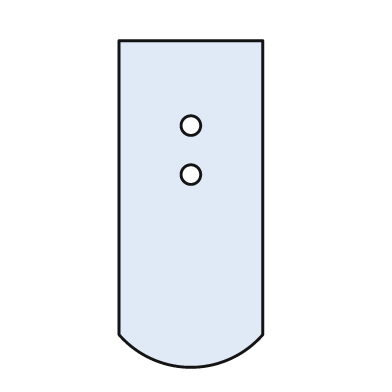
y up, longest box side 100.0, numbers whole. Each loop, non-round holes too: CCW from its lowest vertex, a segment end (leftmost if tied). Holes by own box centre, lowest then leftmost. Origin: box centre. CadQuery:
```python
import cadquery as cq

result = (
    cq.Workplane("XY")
    .moveTo(-22.0, -40.0)
    .threePointArc((0.0, -50.0), (22.0, -40.0))
    .lineTo(22.0, 50.0)
    .lineTo(-22.0, 50.0)
    .close()
    .moveTo(0.0, 9.0)
    .circle(3.0)
    .moveTo(0.0, 24.0)
    .circle(3.0)
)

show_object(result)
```